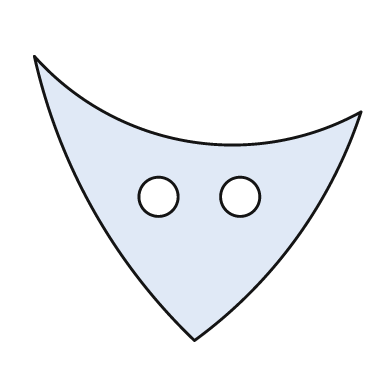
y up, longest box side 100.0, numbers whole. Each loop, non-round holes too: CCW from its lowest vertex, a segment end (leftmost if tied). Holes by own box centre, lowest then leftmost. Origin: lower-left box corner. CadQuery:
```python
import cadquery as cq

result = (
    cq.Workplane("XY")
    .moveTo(49.0, 0.0)
    .threePointArc((80.0, 31.0), (100.0, 70.0))
    .threePointArc((47.0, 61.0), (0.0, 87.0))
    .threePointArc((18.0, 40.0), (49.0, 0.0))
    .close()
    .moveTo(38.0, 44.0)
    .circle(6.0)
    .moveTo(63.0, 44.0)
    .circle(6.0)
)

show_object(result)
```